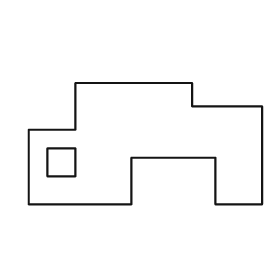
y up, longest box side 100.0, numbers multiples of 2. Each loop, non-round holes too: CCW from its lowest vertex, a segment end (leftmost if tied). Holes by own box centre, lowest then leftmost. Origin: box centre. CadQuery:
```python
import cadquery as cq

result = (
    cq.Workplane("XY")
    .moveTo(-50.0, -26.0)
    .lineTo(-6.0, -26.0)
    .lineTo(-6.0, -6.0)
    .lineTo(30.0, -6.0)
    .lineTo(30.0, -26.0)
    .lineTo(50.0, -26.0)
    .lineTo(50.0, 16.0)
    .lineTo(20.0, 16.0)
    .lineTo(20.0, 26.0)
    .lineTo(-30.0, 26.0)
    .lineTo(-30.0, 6.0)
    .lineTo(-50.0, 6.0)
    .close()
    .moveTo(-42.0, -14.0)
    .lineTo(-30.0, -14.0)
    .lineTo(-30.0, -2.0)
    .lineTo(-42.0, -2.0)
    .close()
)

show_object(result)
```